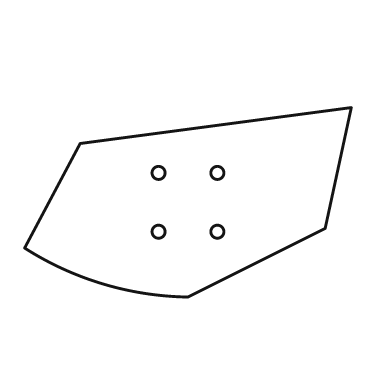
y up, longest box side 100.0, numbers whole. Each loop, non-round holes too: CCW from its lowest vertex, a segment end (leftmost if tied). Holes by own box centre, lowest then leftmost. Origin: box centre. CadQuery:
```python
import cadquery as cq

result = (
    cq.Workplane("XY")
    .moveTo(0.0, -29.0)
    .lineTo(42.0, -8.0)
    .lineTo(50.0, 29.0)
    .lineTo(-33.0, 18.0)
    .lineTo(-50.0, -14.0)
    .threePointArc((-26.0, -25.0), (0.0, -29.0))
    .close()
    .moveTo(-9.0, -9.0)
    .circle(2.0)
    .moveTo(9.0, -9.0)
    .circle(2.0)
    .moveTo(-9.0, 9.0)
    .circle(2.0)
    .moveTo(9.0, 9.0)
    .circle(2.0)
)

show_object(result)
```